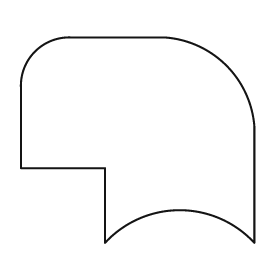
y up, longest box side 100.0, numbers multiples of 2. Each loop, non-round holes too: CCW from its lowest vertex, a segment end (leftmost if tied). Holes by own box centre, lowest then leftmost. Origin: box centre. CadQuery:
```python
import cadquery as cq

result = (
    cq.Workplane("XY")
    .moveTo(-14.0, -44.0)
    .threePointArc((18.0, -30.0), (50.0, -44.0))
    .lineTo(50.0, 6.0)
    .threePointArc((38.0, 32.0), (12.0, 44.0))
    .lineTo(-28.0, 44.0)
    .threePointArc((-44.0, 38.0), (-50.0, 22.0))
    .lineTo(-50.0, -12.0)
    .lineTo(-14.0, -12.0)
    .close()
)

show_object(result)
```